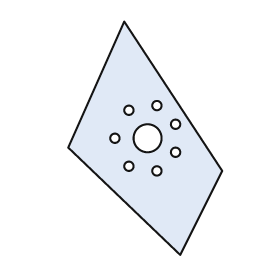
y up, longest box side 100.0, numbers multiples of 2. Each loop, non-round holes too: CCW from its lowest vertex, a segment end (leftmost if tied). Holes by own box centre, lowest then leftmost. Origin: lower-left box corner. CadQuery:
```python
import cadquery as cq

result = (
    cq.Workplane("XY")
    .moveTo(48.0, 0.0)
    .lineTo(66.0, 36.0)
    .lineTo(24.0, 100.0)
    .lineTo(0.0, 46.0)
    .close()
    .moveTo(38.0, 36.0)
    .circle(2.0)
    .moveTo(26.0, 38.0)
    .circle(2.0)
    .moveTo(46.0, 44.0)
    .circle(2.0)
    .moveTo(20.0, 50.0)
    .circle(2.0)
    .moveTo(34.0, 50.0)
    .circle(6.0)
    .moveTo(46.0, 56.0)
    .circle(2.0)
    .moveTo(26.0, 62.0)
    .circle(2.0)
    .moveTo(38.0, 64.0)
    .circle(2.0)
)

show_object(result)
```